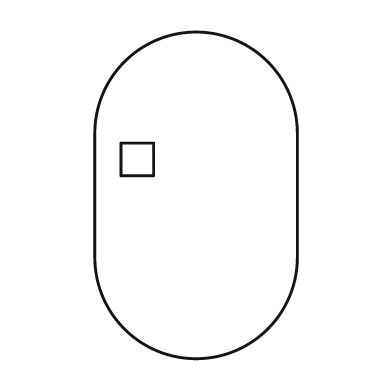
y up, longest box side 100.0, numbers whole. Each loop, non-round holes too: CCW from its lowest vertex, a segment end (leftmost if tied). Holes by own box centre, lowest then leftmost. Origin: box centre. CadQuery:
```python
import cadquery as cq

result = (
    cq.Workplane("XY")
    .moveTo(-31.0, -19.0)
    .threePointArc((0.0, -50.0), (31.0, -19.0))
    .lineTo(31.0, 19.0)
    .threePointArc((0.0, 50.0), (-31.0, 19.0))
    .close()
    .moveTo(-23.0, 6.0)
    .lineTo(-13.0, 6.0)
    .lineTo(-13.0, 16.0)
    .lineTo(-23.0, 16.0)
    .close()
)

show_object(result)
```